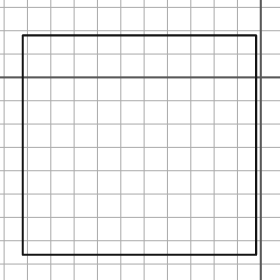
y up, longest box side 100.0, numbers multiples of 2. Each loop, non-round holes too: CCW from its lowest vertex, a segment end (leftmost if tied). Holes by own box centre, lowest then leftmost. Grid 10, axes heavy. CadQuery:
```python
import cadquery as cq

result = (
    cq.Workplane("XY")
    .moveTo(-102.0, -76.0)
    .lineTo(-2.0, -76.0)
    .lineTo(-2.0, 18.0)
    .lineTo(-102.0, 18.0)
    .close()
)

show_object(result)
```